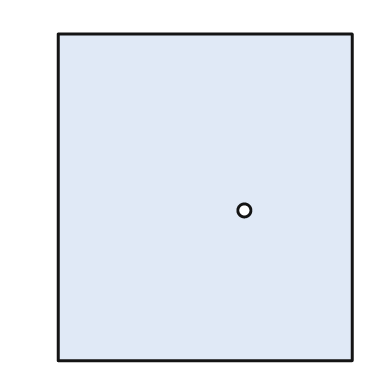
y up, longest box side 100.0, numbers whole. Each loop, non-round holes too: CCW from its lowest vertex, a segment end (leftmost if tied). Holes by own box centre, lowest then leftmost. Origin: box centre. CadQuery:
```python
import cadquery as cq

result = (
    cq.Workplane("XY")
    .moveTo(-45.0, -50.0)
    .lineTo(45.0, -50.0)
    .lineTo(45.0, 50.0)
    .lineTo(-45.0, 50.0)
    .close()
    .moveTo(12.0, -4.0)
    .circle(2.0)
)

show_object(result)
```